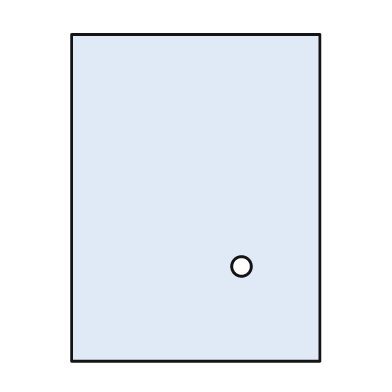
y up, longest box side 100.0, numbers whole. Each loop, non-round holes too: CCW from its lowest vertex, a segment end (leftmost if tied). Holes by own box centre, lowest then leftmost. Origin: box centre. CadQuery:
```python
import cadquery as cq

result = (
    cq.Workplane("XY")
    .moveTo(-38.0, -50.0)
    .lineTo(38.0, -50.0)
    .lineTo(38.0, 50.0)
    .lineTo(-38.0, 50.0)
    .close()
    .moveTo(14.0, -21.0)
    .circle(3.0)
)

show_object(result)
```